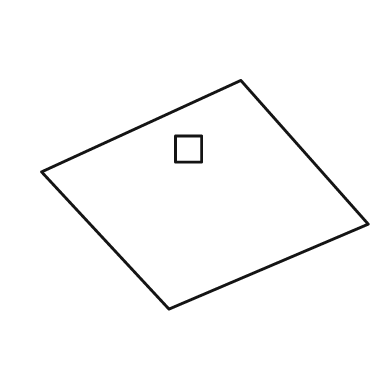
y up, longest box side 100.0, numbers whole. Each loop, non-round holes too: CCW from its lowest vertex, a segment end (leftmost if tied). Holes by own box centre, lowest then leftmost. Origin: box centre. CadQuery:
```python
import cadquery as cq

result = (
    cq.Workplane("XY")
    .moveTo(-11.0, -35.0)
    .lineTo(50.0, -9.0)
    .lineTo(11.0, 35.0)
    .lineTo(-50.0, 7.0)
    .close()
    .moveTo(-9.0, 10.0)
    .lineTo(-1.0, 10.0)
    .lineTo(-1.0, 18.0)
    .lineTo(-9.0, 18.0)
    .close()
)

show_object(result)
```